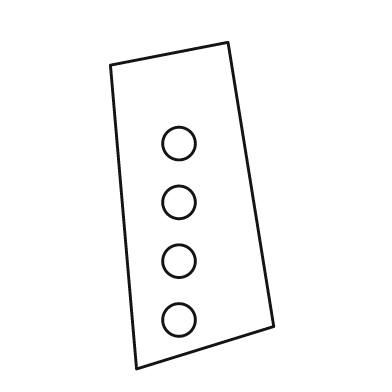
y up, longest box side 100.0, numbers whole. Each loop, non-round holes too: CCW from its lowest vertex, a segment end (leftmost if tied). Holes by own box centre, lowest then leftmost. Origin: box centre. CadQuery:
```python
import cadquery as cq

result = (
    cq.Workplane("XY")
    .moveTo(-17.0, -50.0)
    .lineTo(25.0, -37.0)
    .lineTo(11.0, 50.0)
    .lineTo(-25.0, 43.0)
    .close()
    .moveTo(-4.0, -35.0)
    .circle(5.0)
    .moveTo(-4.0, -17.0)
    .circle(5.0)
    .moveTo(-4.0, 1.0)
    .circle(5.0)
    .moveTo(-4.0, 19.0)
    .circle(5.0)
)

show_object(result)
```